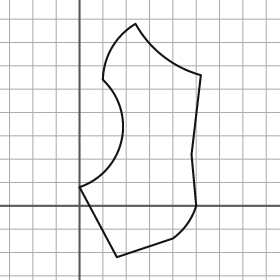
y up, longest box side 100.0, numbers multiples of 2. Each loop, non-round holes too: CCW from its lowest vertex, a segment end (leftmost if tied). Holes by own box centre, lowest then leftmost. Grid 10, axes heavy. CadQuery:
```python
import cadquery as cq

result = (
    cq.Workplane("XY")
    .moveTo(16.0, -22.0)
    .lineTo(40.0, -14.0)
    .threePointArc((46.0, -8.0), (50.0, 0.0))
    .lineTo(48.0, 22.0)
    .lineTo(52.0, 56.0)
    .threePointArc((36.0, 64.0), (24.0, 78.0))
    .threePointArc((14.0, 68.0), (10.0, 54.0))
    .threePointArc((18.0, 28.0), (0.0, 8.0))
    .close()
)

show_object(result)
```